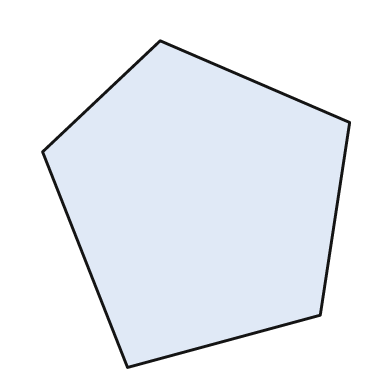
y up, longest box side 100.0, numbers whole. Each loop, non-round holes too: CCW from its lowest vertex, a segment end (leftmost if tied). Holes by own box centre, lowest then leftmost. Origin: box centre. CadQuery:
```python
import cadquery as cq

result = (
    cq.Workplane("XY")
    .moveTo(-21.0, -50.0)
    .lineTo(38.0, -34.0)
    .lineTo(47.0, 25.0)
    .lineTo(-11.0, 50.0)
    .lineTo(-47.0, 16.0)
    .close()
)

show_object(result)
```